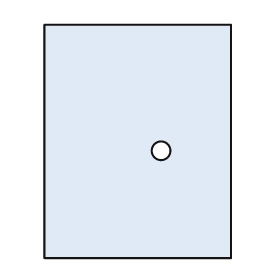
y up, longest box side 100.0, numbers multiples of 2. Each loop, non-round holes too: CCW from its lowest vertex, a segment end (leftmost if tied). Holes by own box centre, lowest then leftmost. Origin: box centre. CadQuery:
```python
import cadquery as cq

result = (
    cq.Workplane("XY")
    .moveTo(-40.0, -50.0)
    .lineTo(40.0, -50.0)
    .lineTo(40.0, 50.0)
    .lineTo(-40.0, 50.0)
    .close()
    .moveTo(10.0, -4.0)
    .circle(4.0)
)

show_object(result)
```